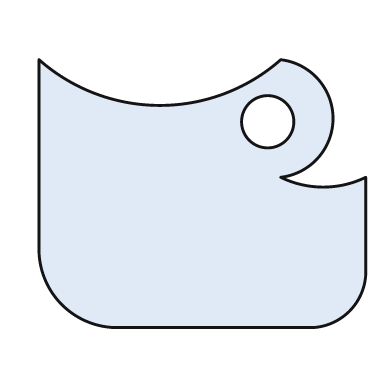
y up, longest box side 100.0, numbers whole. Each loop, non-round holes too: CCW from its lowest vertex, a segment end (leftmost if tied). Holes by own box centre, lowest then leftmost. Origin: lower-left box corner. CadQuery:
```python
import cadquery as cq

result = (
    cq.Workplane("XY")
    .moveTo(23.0, 0.0)
    .lineTo(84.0, 0.0)
    .threePointArc((95.0, 5.0), (100.0, 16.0))
    .lineTo(100.0, 46.0)
    .threePointArc((87.0, 43.0), (74.0, 46.0))
    .threePointArc((90.0, 64.0), (74.0, 82.0))
    .threePointArc((37.0, 68.0), (0.0, 82.0))
    .lineTo(0.0, 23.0)
    .threePointArc((7.0, 7.0), (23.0, 0.0))
    .close()
    .moveTo(70.0, 63.0)
    .circle(8.0)
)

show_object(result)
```